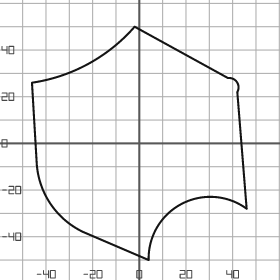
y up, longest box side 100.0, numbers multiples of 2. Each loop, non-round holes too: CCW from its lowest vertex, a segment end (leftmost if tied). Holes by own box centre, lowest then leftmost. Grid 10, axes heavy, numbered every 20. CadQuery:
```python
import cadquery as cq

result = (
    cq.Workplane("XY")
    .moveTo(4.0, -50.0)
    .threePointArc((18.0, -26.0), (46.0, -28.0))
    .lineTo(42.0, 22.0)
    .threePointArc((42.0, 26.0), (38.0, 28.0))
    .lineTo(-2.0, 50.0)
    .threePointArc((-22.0, 34.0), (-46.0, 26.0))
    .lineTo(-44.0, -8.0)
    .threePointArc((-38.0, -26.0), (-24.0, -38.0))
    .close()
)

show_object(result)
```